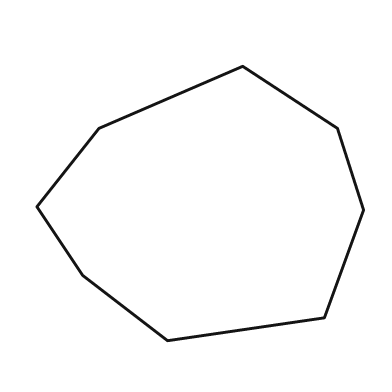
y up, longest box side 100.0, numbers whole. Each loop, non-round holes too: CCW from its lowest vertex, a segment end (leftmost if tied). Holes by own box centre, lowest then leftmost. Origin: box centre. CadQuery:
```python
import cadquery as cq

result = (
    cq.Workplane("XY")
    .moveTo(-10.0, -42.0)
    .lineTo(38.0, -35.0)
    .lineTo(50.0, -2.0)
    .lineTo(42.0, 23.0)
    .lineTo(13.0, 42.0)
    .lineTo(-31.0, 23.0)
    .lineTo(-50.0, -1.0)
    .lineTo(-36.0, -22.0)
    .close()
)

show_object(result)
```